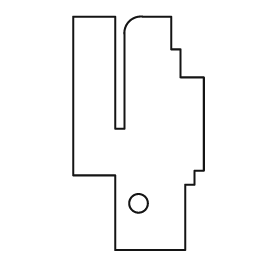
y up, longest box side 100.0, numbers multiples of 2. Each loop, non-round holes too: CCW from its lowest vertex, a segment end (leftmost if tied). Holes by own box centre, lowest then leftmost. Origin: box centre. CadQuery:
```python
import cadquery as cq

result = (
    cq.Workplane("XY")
    .moveTo(-10.0, -50.0)
    .lineTo(20.0, -50.0)
    .lineTo(20.0, -22.0)
    .lineTo(24.0, -22.0)
    .lineTo(24.0, -16.0)
    .lineTo(28.0, -16.0)
    .lineTo(28.0, 24.0)
    .lineTo(18.0, 24.0)
    .lineTo(18.0, 36.0)
    .lineTo(14.0, 36.0)
    .lineTo(14.0, 50.0)
    .lineTo(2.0, 50.0)
    .threePointArc((-4.0, 48.0), (-6.0, 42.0))
    .lineTo(-6.0, 2.0)
    .lineTo(-10.0, 2.0)
    .lineTo(-10.0, 50.0)
    .lineTo(-28.0, 50.0)
    .lineTo(-28.0, -18.0)
    .lineTo(-10.0, -18.0)
    .close()
    .moveTo(0.0, -30.0)
    .circle(4.0)
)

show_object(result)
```